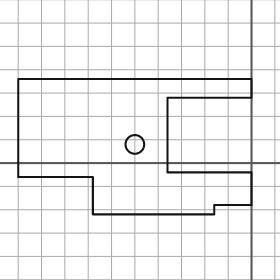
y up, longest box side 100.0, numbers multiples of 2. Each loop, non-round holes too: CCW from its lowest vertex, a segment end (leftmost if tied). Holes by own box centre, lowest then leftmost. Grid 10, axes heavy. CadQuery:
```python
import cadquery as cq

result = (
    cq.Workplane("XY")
    .moveTo(-68.0, -22.0)
    .lineTo(-16.0, -22.0)
    .lineTo(-16.0, -18.0)
    .lineTo(0.0, -18.0)
    .lineTo(0.0, -4.0)
    .lineTo(-36.0, -4.0)
    .lineTo(-36.0, 28.0)
    .lineTo(0.0, 28.0)
    .lineTo(0.0, 36.0)
    .lineTo(-100.0, 36.0)
    .lineTo(-100.0, -6.0)
    .lineTo(-68.0, -6.0)
    .close()
    .moveTo(-50.0, 8.0)
    .circle(4.0)
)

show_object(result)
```